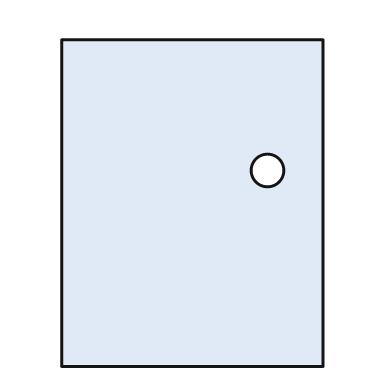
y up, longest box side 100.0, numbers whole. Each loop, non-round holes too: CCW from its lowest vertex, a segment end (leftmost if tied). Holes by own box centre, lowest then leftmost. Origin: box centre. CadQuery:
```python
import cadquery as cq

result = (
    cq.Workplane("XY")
    .moveTo(-40.0, -50.0)
    .lineTo(40.0, -50.0)
    .lineTo(40.0, 50.0)
    .lineTo(-40.0, 50.0)
    .close()
    .moveTo(23.0, 10.0)
    .circle(5.0)
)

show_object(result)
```